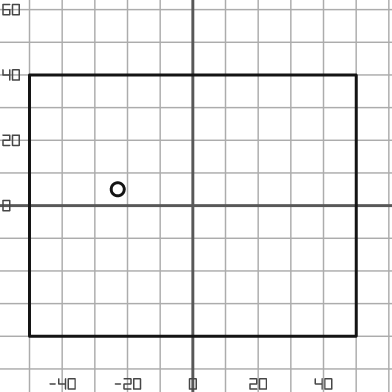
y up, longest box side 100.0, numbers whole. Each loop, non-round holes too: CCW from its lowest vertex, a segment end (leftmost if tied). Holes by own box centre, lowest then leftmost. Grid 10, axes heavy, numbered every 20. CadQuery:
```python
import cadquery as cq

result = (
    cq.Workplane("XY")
    .moveTo(-50.0, -40.0)
    .lineTo(50.0, -40.0)
    .lineTo(50.0, 40.0)
    .lineTo(-50.0, 40.0)
    .close()
    .moveTo(-23.0, 5.0)
    .circle(2.0)
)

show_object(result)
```